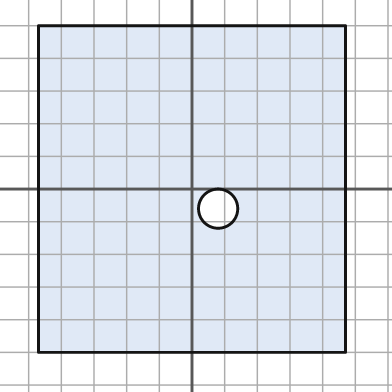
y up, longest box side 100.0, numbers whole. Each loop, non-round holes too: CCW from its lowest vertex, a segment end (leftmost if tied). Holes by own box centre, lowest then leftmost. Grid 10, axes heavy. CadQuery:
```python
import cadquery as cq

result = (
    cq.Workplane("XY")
    .moveTo(-47.0, -50.0)
    .lineTo(47.0, -50.0)
    .lineTo(47.0, 50.0)
    .lineTo(-47.0, 50.0)
    .close()
    .moveTo(8.0, -6.0)
    .circle(6.0)
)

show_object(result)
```